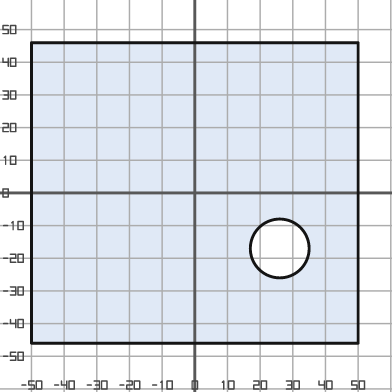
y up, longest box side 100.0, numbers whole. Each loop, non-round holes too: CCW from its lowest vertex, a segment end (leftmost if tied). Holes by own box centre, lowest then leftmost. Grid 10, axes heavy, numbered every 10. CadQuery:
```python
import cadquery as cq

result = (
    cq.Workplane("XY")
    .moveTo(-50.0, -46.0)
    .lineTo(50.0, -46.0)
    .lineTo(50.0, 46.0)
    .lineTo(-50.0, 46.0)
    .close()
    .moveTo(26.0, -17.0)
    .circle(9.0)
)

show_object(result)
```